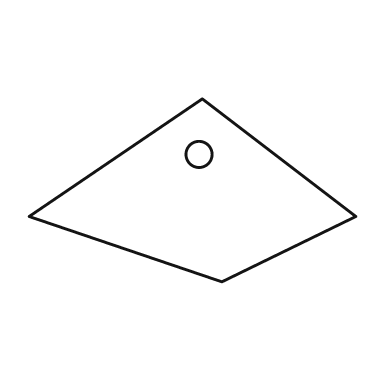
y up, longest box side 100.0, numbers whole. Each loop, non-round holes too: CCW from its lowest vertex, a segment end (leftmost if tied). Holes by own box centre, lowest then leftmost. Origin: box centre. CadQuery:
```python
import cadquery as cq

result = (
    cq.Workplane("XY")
    .moveTo(9.0, -28.0)
    .lineTo(50.0, -8.0)
    .lineTo(3.0, 28.0)
    .lineTo(-50.0, -8.0)
    .close()
    .moveTo(2.0, 11.0)
    .circle(4.0)
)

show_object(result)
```